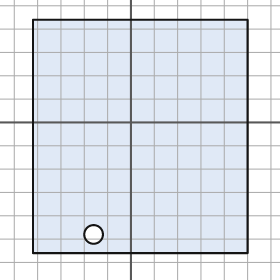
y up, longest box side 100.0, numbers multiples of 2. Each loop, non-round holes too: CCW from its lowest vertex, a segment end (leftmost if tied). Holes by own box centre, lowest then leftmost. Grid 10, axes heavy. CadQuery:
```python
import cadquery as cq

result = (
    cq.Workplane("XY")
    .moveTo(-42.0, -56.0)
    .lineTo(50.0, -56.0)
    .lineTo(50.0, 44.0)
    .lineTo(-42.0, 44.0)
    .close()
    .moveTo(-16.0, -48.0)
    .circle(4.0)
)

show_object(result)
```